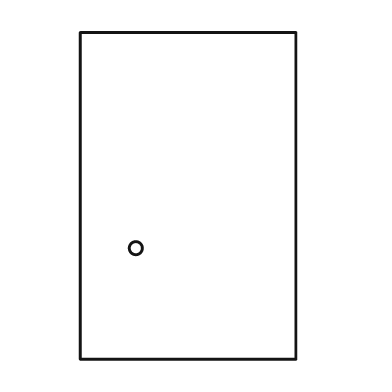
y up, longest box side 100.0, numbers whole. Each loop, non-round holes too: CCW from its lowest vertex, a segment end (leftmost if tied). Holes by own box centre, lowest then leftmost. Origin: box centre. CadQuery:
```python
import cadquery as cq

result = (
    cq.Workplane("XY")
    .moveTo(-33.0, -50.0)
    .lineTo(33.0, -50.0)
    .lineTo(33.0, 50.0)
    .lineTo(-33.0, 50.0)
    .close()
    .moveTo(-16.0, -16.0)
    .circle(2.0)
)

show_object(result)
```